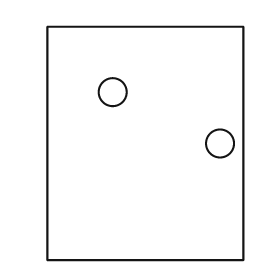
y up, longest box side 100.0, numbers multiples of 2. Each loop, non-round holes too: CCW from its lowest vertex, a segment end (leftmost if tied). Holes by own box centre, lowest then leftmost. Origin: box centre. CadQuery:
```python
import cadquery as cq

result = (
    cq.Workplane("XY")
    .moveTo(-42.0, -50.0)
    .lineTo(42.0, -50.0)
    .lineTo(42.0, 50.0)
    .lineTo(-42.0, 50.0)
    .close()
    .moveTo(32.0, 0.0)
    .circle(6.0)
    .moveTo(-14.0, 22.0)
    .circle(6.0)
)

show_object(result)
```